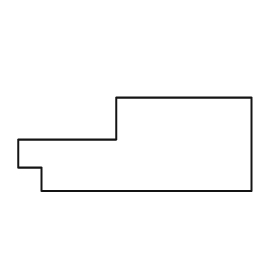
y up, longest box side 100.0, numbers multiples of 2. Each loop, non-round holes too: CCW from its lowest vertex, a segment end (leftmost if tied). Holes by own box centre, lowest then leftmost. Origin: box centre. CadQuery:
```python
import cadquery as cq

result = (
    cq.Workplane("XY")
    .moveTo(-40.0, -20.0)
    .lineTo(50.0, -20.0)
    .lineTo(50.0, 20.0)
    .lineTo(-8.0, 20.0)
    .lineTo(-8.0, 2.0)
    .lineTo(-50.0, 2.0)
    .lineTo(-50.0, -10.0)
    .lineTo(-40.0, -10.0)
    .close()
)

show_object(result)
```